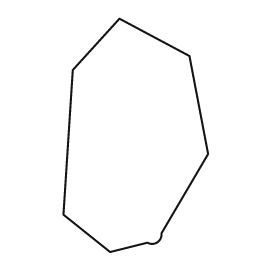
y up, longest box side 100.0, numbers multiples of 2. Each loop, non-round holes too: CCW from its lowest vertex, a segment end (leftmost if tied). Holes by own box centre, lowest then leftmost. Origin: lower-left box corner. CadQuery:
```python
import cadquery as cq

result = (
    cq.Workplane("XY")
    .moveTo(20.0, 0.0)
    .lineTo(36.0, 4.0)
    .threePointArc((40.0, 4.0), (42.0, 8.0))
    .lineTo(62.0, 42.0)
    .lineTo(54.0, 84.0)
    .lineTo(24.0, 100.0)
    .lineTo(4.0, 78.0)
    .lineTo(0.0, 16.0)
    .close()
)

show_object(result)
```